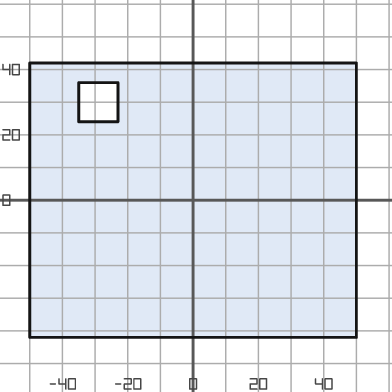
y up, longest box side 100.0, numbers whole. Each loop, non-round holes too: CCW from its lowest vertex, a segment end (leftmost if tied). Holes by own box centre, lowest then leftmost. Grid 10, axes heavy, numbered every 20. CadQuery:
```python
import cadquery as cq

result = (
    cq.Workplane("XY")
    .moveTo(-50.0, -42.0)
    .lineTo(50.0, -42.0)
    .lineTo(50.0, 42.0)
    .lineTo(-50.0, 42.0)
    .close()
    .moveTo(-35.0, 24.0)
    .lineTo(-23.0, 24.0)
    .lineTo(-23.0, 36.0)
    .lineTo(-35.0, 36.0)
    .close()
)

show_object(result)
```